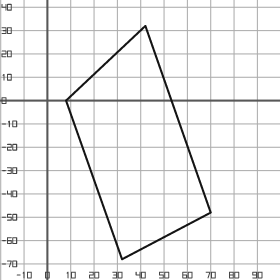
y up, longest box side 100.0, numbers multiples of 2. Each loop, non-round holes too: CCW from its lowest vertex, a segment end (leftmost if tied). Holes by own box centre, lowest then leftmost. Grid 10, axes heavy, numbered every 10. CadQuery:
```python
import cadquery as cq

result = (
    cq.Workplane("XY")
    .moveTo(32.0, -68.0)
    .lineTo(70.0, -48.0)
    .lineTo(42.0, 32.0)
    .lineTo(8.0, 0.0)
    .close()
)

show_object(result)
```